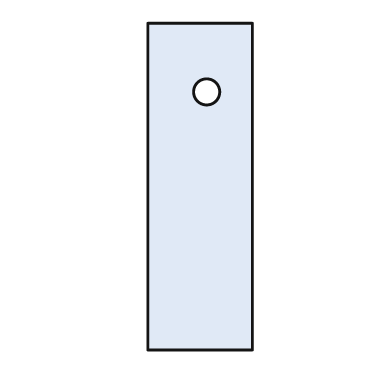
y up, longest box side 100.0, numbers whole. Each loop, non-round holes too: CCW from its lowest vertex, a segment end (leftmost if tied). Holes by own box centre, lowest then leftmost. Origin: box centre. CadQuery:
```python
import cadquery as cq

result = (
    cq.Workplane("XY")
    .moveTo(-16.0, -50.0)
    .lineTo(16.0, -50.0)
    .lineTo(16.0, 50.0)
    .lineTo(-16.0, 50.0)
    .close()
    .moveTo(2.0, 29.0)
    .circle(4.0)
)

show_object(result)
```